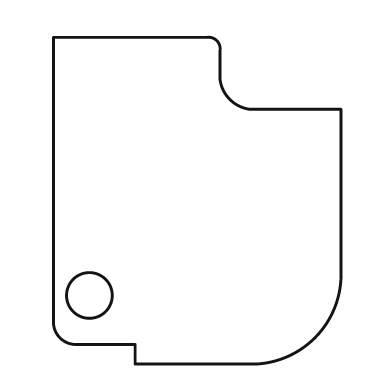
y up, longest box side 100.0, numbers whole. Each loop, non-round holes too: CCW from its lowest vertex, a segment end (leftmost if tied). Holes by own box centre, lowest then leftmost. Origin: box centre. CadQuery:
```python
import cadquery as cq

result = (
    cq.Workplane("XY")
    .moveTo(-19.0, -50.0)
    .lineTo(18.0, -50.0)
    .threePointArc((36.0, -42.0), (44.0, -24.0))
    .lineTo(44.0, 28.0)
    .lineTo(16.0, 28.0)
    .threePointArc((10.0, 31.0), (7.0, 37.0))
    .lineTo(7.0, 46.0)
    .threePointArc((6.0, 49.0), (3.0, 50.0))
    .lineTo(-44.0, 50.0)
    .lineTo(-44.0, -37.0)
    .threePointArc((-42.0, -42.0), (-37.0, -44.0))
    .lineTo(-19.0, -44.0)
    .close()
    .moveTo(-33.0, -29.0)
    .circle(7.0)
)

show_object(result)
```